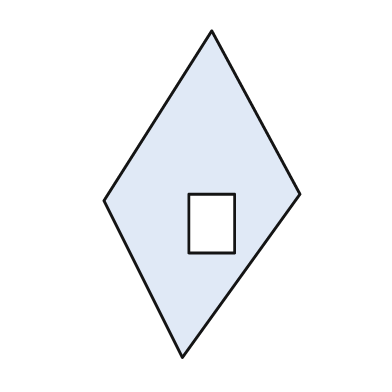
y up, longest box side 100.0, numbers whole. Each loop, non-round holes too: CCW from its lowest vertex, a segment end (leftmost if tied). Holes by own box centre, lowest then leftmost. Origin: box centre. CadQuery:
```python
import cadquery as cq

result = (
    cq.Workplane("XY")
    .moveTo(-6.0, -50.0)
    .lineTo(30.0, 0.0)
    .lineTo(3.0, 50.0)
    .lineTo(-30.0, -2.0)
    .close()
    .moveTo(-4.0, -18.0)
    .lineTo(10.0, -18.0)
    .lineTo(10.0, 0.0)
    .lineTo(-4.0, 0.0)
    .close()
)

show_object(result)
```